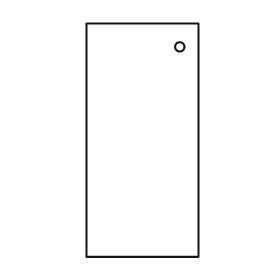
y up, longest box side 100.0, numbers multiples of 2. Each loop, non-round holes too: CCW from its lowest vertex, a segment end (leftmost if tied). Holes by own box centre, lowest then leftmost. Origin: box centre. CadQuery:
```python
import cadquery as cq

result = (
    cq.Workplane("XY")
    .moveTo(-24.0, -50.0)
    .lineTo(24.0, -50.0)
    .lineTo(24.0, 50.0)
    .lineTo(-24.0, 50.0)
    .close()
    .moveTo(16.0, 40.0)
    .circle(2.0)
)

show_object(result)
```